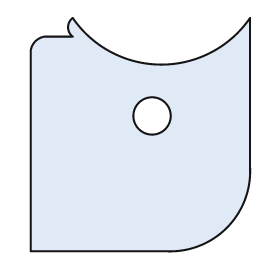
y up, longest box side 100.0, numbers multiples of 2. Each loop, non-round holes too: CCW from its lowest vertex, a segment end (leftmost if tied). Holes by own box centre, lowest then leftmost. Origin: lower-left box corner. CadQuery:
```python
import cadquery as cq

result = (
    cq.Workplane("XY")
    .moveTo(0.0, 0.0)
    .lineTo(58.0, 0.0)
    .threePointArc((84.0, 10.0), (94.0, 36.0))
    .lineTo(94.0, 100.0)
    .threePointArc((56.0, 80.0), (18.0, 100.0))
    .threePointArc((16.0, 96.0), (18.0, 92.0))
    .lineTo(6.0, 92.0)
    .threePointArc((2.0, 90.0), (0.0, 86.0))
    .close()
    .moveTo(52.0, 58.0)
    .circle(8.0)
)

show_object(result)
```